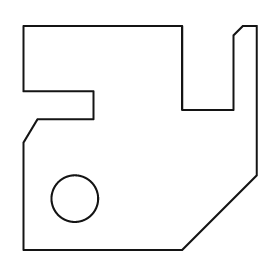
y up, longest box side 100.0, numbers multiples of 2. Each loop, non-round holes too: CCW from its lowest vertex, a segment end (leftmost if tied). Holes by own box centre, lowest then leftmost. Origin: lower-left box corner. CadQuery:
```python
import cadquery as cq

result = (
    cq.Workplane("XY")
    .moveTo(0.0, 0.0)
    .lineTo(68.0, 0.0)
    .lineTo(100.0, 32.0)
    .lineTo(100.0, 96.0)
    .lineTo(94.0, 96.0)
    .lineTo(90.0, 92.0)
    .lineTo(90.0, 60.0)
    .lineTo(68.0, 60.0)
    .lineTo(68.0, 96.0)
    .lineTo(0.0, 96.0)
    .lineTo(0.0, 68.0)
    .lineTo(30.0, 68.0)
    .lineTo(30.0, 56.0)
    .lineTo(6.0, 56.0)
    .lineTo(0.0, 46.0)
    .close()
    .moveTo(22.0, 22.0)
    .circle(10.0)
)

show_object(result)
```